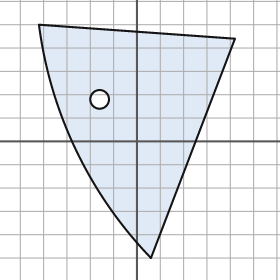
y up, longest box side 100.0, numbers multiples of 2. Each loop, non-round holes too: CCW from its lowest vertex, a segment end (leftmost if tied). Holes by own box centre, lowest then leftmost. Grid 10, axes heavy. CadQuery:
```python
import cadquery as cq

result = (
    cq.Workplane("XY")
    .moveTo(6.0, -50.0)
    .lineTo(42.0, 44.0)
    .lineTo(-42.0, 50.0)
    .threePointArc((-26.0, -4.0), (6.0, -50.0))
    .close()
    .moveTo(-16.0, 18.0)
    .circle(4.0)
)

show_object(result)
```